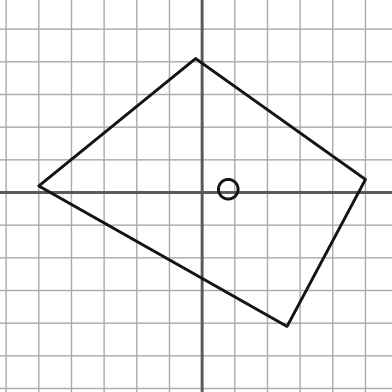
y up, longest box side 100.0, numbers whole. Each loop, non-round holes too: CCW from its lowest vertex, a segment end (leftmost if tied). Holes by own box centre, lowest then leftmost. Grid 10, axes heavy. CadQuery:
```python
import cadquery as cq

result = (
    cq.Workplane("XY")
    .moveTo(26.0, -41.0)
    .lineTo(50.0, 4.0)
    .lineTo(-2.0, 41.0)
    .lineTo(-50.0, 2.0)
    .close()
    .moveTo(8.0, 1.0)
    .circle(3.0)
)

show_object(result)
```